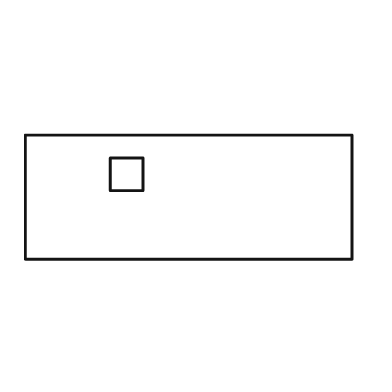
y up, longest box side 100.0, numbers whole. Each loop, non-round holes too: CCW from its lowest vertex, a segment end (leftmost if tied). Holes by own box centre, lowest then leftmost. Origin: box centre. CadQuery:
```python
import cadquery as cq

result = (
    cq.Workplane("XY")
    .moveTo(-50.0, -19.0)
    .lineTo(50.0, -19.0)
    .lineTo(50.0, 19.0)
    .lineTo(-50.0, 19.0)
    .close()
    .moveTo(-24.0, 2.0)
    .lineTo(-14.0, 2.0)
    .lineTo(-14.0, 12.0)
    .lineTo(-24.0, 12.0)
    .close()
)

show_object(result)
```